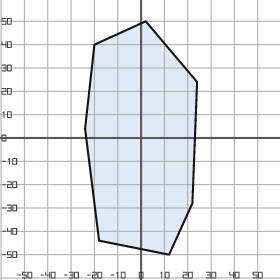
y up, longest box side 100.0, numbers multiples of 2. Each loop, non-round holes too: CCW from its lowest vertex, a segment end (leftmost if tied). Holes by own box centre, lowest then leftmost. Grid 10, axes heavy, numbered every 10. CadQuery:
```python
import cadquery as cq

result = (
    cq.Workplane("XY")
    .moveTo(12.0, -50.0)
    .lineTo(22.0, -28.0)
    .lineTo(24.0, 24.0)
    .lineTo(2.0, 50.0)
    .lineTo(-20.0, 40.0)
    .lineTo(-24.0, 4.0)
    .lineTo(-18.0, -44.0)
    .close()
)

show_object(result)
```